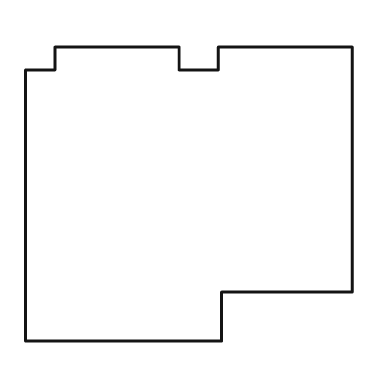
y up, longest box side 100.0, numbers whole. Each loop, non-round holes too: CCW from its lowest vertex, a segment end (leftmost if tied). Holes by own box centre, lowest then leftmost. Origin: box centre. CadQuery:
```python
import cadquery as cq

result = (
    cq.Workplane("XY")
    .moveTo(-50.0, -45.0)
    .lineTo(10.0, -45.0)
    .lineTo(10.0, -30.0)
    .lineTo(50.0, -30.0)
    .lineTo(50.0, 45.0)
    .lineTo(9.0, 45.0)
    .lineTo(9.0, 38.0)
    .lineTo(-3.0, 38.0)
    .lineTo(-3.0, 45.0)
    .lineTo(-41.0, 45.0)
    .lineTo(-41.0, 38.0)
    .lineTo(-50.0, 38.0)
    .close()
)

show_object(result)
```